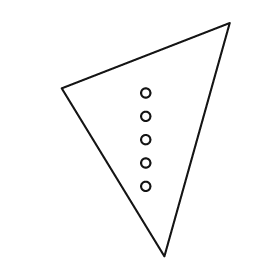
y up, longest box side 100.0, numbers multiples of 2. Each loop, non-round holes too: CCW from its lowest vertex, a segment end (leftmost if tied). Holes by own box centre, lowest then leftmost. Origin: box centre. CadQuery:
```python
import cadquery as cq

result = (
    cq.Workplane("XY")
    .moveTo(8.0, -50.0)
    .lineTo(36.0, 50.0)
    .lineTo(-36.0, 22.0)
    .close()
    .moveTo(0.0, -20.0)
    .circle(2.0)
    .moveTo(0.0, -10.0)
    .circle(2.0)
    .moveTo(0.0, 0.0)
    .circle(2.0)
    .moveTo(0.0, 10.0)
    .circle(2.0)
    .moveTo(0.0, 20.0)
    .circle(2.0)
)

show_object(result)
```